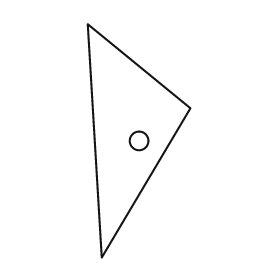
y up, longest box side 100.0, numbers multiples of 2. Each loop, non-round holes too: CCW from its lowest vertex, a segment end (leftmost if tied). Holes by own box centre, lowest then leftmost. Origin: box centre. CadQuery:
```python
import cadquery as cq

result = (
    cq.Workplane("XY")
    .moveTo(-16.0, -50.0)
    .lineTo(22.0, 14.0)
    .lineTo(-22.0, 50.0)
    .close()
    .moveTo(0.0, 0.0)
    .circle(4.0)
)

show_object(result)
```